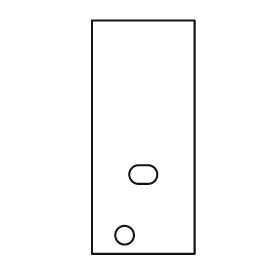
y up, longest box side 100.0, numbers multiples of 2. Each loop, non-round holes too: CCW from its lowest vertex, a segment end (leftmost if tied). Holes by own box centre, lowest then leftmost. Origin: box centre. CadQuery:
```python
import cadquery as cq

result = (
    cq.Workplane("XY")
    .moveTo(-22.0, -50.0)
    .lineTo(22.0, -50.0)
    .lineTo(22.0, 50.0)
    .lineTo(-22.0, 50.0)
    .close()
    .moveTo(-8.0, -42.0)
    .circle(4.0)
    .moveTo(-2.0, -20.0)
    .lineTo(2.0, -20.0)
    .threePointArc((6.0, -16.0), (2.0, -12.0))
    .lineTo(-2.0, -12.0)
    .threePointArc((-6.0, -16.0), (-2.0, -20.0))
    .close()
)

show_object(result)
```